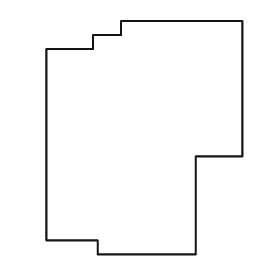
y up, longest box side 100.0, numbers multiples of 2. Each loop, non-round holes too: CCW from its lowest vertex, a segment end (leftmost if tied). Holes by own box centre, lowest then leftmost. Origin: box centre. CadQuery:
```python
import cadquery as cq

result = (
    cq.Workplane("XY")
    .moveTo(-20.0, -50.0)
    .lineTo(22.0, -50.0)
    .lineTo(22.0, -8.0)
    .lineTo(42.0, -8.0)
    .lineTo(42.0, 50.0)
    .lineTo(-10.0, 50.0)
    .lineTo(-10.0, 44.0)
    .lineTo(-22.0, 44.0)
    .lineTo(-22.0, 38.0)
    .lineTo(-42.0, 38.0)
    .lineTo(-42.0, -44.0)
    .lineTo(-20.0, -44.0)
    .close()
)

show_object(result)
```